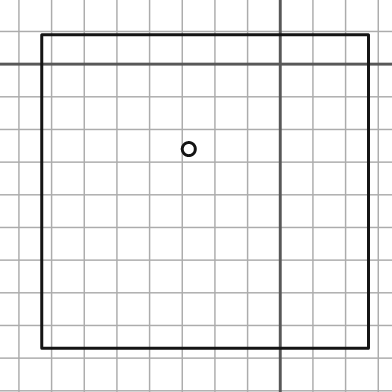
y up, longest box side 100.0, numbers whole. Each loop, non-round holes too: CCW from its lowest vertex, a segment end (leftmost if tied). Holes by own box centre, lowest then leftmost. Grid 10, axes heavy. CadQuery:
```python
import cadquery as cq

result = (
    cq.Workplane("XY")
    .moveTo(-73.0, -87.0)
    .lineTo(27.0, -87.0)
    .lineTo(27.0, 9.0)
    .lineTo(-73.0, 9.0)
    .close()
    .moveTo(-28.0, -26.0)
    .circle(2.0)
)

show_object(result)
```